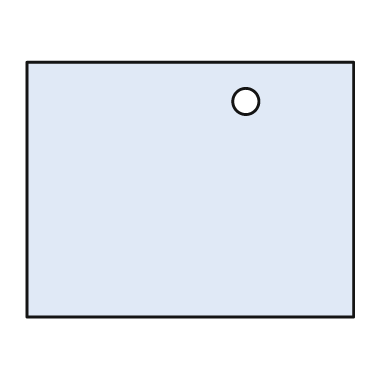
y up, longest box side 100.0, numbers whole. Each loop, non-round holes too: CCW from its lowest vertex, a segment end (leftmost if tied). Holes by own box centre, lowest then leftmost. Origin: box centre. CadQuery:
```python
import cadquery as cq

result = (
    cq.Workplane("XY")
    .moveTo(-50.0, -39.0)
    .lineTo(50.0, -39.0)
    .lineTo(50.0, 39.0)
    .lineTo(-50.0, 39.0)
    .close()
    .moveTo(17.0, 27.0)
    .circle(4.0)
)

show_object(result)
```